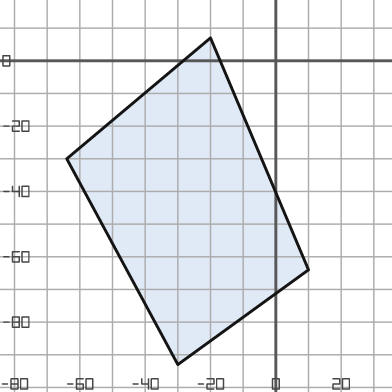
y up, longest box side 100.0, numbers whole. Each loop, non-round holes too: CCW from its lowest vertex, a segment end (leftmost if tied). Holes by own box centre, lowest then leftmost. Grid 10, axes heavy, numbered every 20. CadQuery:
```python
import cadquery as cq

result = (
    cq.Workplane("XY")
    .moveTo(-30.0, -93.0)
    .lineTo(10.0, -64.0)
    .lineTo(-20.0, 7.0)
    .lineTo(-64.0, -30.0)
    .close()
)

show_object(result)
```